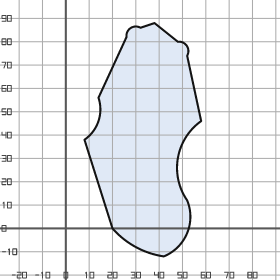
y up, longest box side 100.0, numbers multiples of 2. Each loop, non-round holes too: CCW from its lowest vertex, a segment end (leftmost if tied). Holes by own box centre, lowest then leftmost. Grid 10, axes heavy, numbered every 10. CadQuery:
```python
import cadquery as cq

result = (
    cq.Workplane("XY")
    .moveTo(42.0, -12.0)
    .threePointArc((52.0, -2.0), (52.0, 12.0))
    .threePointArc((48.0, 30.0), (58.0, 46.0))
    .lineTo(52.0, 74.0)
    .threePointArc((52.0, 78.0), (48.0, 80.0))
    .lineTo(38.0, 88.0)
    .lineTo(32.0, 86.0)
    .threePointArc((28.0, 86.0), (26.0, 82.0))
    .lineTo(14.0, 56.0)
    .threePointArc((14.0, 46.0), (8.0, 38.0))
    .lineTo(20.0, 0.0)
    .threePointArc((30.0, -8.0), (42.0, -12.0))
    .close()
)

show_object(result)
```